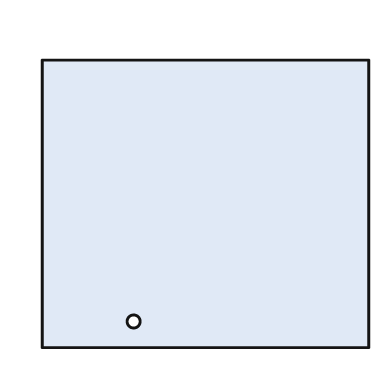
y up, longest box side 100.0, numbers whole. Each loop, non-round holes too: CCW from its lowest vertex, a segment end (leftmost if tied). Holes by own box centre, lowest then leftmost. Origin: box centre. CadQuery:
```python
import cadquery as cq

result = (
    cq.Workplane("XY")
    .moveTo(-50.0, -44.0)
    .lineTo(50.0, -44.0)
    .lineTo(50.0, 44.0)
    .lineTo(-50.0, 44.0)
    .close()
    .moveTo(-22.0, -36.0)
    .circle(2.0)
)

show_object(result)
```